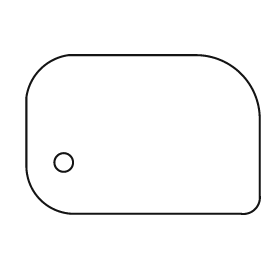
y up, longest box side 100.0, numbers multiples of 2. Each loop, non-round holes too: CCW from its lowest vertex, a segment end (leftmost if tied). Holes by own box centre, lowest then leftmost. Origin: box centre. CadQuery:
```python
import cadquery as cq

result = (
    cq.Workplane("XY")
    .moveTo(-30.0, -34.0)
    .lineTo(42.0, -34.0)
    .threePointArc((48.0, -32.0), (50.0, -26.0))
    .lineTo(50.0, 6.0)
    .threePointArc((42.0, 26.0), (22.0, 34.0))
    .lineTo(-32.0, 34.0)
    .threePointArc((-44.0, 28.0), (-50.0, 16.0))
    .lineTo(-50.0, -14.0)
    .threePointArc((-44.0, -28.0), (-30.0, -34.0))
    .close()
    .moveTo(-34.0, -12.0)
    .circle(4.0)
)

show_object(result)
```